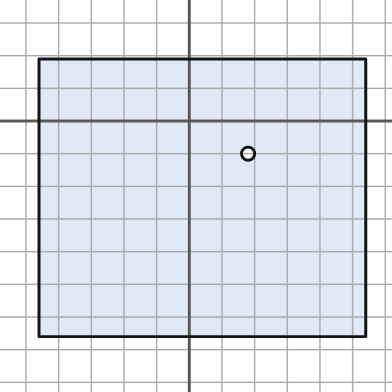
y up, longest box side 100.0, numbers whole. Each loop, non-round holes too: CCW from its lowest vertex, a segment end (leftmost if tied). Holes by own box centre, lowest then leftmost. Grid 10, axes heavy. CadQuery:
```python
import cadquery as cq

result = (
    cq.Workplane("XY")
    .moveTo(-46.0, -66.0)
    .lineTo(54.0, -66.0)
    .lineTo(54.0, 19.0)
    .lineTo(-46.0, 19.0)
    .close()
    .moveTo(18.0, -10.0)
    .circle(2.0)
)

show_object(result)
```